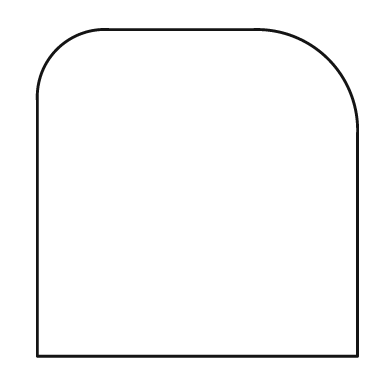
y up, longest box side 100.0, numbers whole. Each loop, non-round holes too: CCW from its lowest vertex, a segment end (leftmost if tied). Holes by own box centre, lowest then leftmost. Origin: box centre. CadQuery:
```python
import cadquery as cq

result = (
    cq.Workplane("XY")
    .moveTo(-49.0, -50.0)
    .lineTo(49.0, -50.0)
    .lineTo(49.0, 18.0)
    .threePointArc((40.0, 41.0), (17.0, 50.0))
    .lineTo(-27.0, 50.0)
    .threePointArc((-43.0, 44.0), (-49.0, 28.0))
    .close()
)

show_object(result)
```